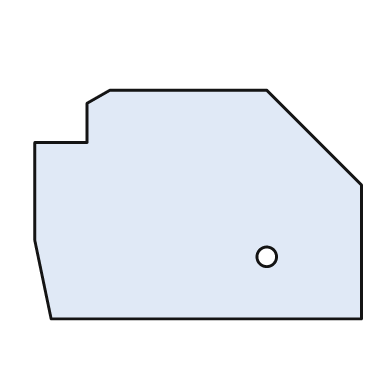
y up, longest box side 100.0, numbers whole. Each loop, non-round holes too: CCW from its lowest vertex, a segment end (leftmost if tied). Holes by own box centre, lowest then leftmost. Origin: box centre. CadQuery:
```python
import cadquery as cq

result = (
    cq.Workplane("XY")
    .moveTo(-45.0, -35.0)
    .lineTo(50.0, -35.0)
    .lineTo(50.0, 6.0)
    .lineTo(21.0, 35.0)
    .lineTo(-27.0, 35.0)
    .lineTo(-34.0, 31.0)
    .lineTo(-34.0, 19.0)
    .lineTo(-50.0, 19.0)
    .lineTo(-50.0, -11.0)
    .close()
    .moveTo(21.0, -16.0)
    .circle(3.0)
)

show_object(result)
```